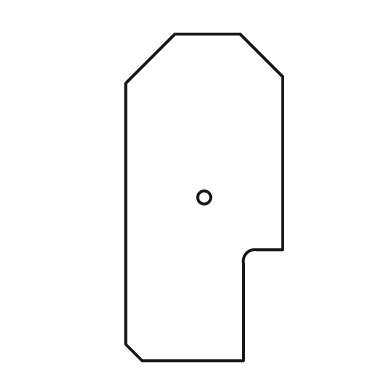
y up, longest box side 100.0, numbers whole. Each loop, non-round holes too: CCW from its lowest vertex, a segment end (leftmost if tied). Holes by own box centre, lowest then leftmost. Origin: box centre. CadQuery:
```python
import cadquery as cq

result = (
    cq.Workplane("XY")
    .moveTo(-19.0, -50.0)
    .lineTo(12.0, -50.0)
    .lineTo(12.0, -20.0)
    .threePointArc((13.0, -17.0), (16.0, -16.0))
    .lineTo(24.0, -16.0)
    .lineTo(24.0, 37.0)
    .lineTo(11.0, 50.0)
    .lineTo(-9.0, 50.0)
    .lineTo(-24.0, 35.0)
    .lineTo(-24.0, -45.0)
    .close()
    .moveTo(0.0, 0.0)
    .circle(2.0)
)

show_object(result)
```